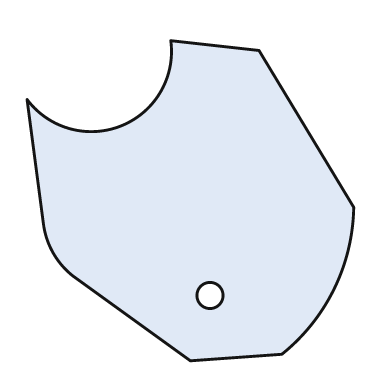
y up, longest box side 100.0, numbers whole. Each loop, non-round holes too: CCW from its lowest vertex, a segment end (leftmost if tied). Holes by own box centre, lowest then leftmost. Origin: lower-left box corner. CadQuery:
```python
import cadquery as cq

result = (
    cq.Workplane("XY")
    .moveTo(50.0, 0.0)
    .lineTo(78.0, 2.0)
    .threePointArc((94.0, 22.0), (100.0, 47.0))
    .lineTo(71.0, 95.0)
    .lineTo(44.0, 98.0)
    .threePointArc((29.0, 72.0), (0.0, 80.0))
    .lineTo(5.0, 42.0)
    .threePointArc((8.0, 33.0), (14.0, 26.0))
    .close()
    .moveTo(56.0, 20.0)
    .circle(4.0)
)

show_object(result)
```